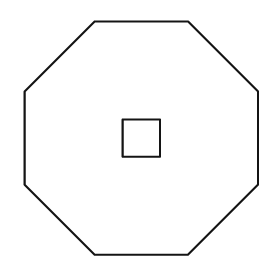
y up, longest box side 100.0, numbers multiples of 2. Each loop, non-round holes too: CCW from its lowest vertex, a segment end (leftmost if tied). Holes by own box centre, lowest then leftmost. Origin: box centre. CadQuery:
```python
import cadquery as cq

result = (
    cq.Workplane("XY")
    .moveTo(-20.0, -50.0)
    .lineTo(20.0, -50.0)
    .lineTo(50.0, -20.0)
    .lineTo(50.0, 20.0)
    .lineTo(20.0, 50.0)
    .lineTo(-20.0, 50.0)
    .lineTo(-50.0, 20.0)
    .lineTo(-50.0, -20.0)
    .close()
    .moveTo(-8.0, -8.0)
    .lineTo(8.0, -8.0)
    .lineTo(8.0, 8.0)
    .lineTo(-8.0, 8.0)
    .close()
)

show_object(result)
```